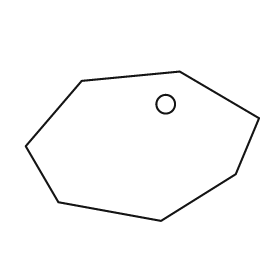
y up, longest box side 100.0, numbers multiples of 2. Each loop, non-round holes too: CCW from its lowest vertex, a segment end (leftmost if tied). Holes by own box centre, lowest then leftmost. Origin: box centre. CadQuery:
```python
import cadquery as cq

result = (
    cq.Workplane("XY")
    .moveTo(8.0, -32.0)
    .lineTo(40.0, -12.0)
    .lineTo(50.0, 12.0)
    .lineTo(16.0, 32.0)
    .lineTo(-26.0, 28.0)
    .lineTo(-50.0, 0.0)
    .lineTo(-36.0, -24.0)
    .close()
    .moveTo(10.0, 18.0)
    .circle(4.0)
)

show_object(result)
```